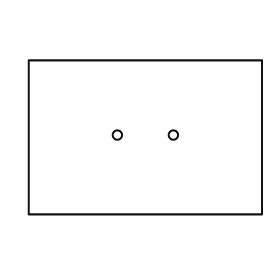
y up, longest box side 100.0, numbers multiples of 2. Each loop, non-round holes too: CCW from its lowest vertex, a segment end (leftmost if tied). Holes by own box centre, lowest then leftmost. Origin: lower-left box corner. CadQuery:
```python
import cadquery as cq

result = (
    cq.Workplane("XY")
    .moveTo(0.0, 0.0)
    .lineTo(100.0, 0.0)
    .lineTo(100.0, 66.0)
    .lineTo(0.0, 66.0)
    .close()
    .moveTo(38.0, 34.0)
    .circle(2.0)
    .moveTo(62.0, 34.0)
    .circle(2.0)
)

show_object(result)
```